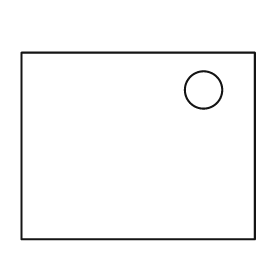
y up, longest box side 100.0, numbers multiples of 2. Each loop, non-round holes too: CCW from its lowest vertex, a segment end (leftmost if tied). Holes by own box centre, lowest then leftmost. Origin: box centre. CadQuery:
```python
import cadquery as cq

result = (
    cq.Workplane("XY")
    .moveTo(-50.0, -40.0)
    .lineTo(50.0, -40.0)
    .lineTo(50.0, 40.0)
    .lineTo(-50.0, 40.0)
    .close()
    .moveTo(28.0, 24.0)
    .circle(8.0)
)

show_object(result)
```